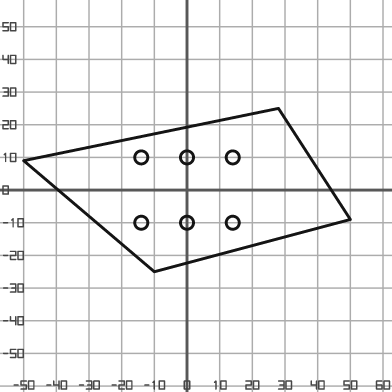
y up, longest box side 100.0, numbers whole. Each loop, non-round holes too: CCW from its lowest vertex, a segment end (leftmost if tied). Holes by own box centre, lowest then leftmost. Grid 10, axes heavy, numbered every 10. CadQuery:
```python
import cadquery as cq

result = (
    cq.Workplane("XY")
    .moveTo(-10.0, -25.0)
    .lineTo(50.0, -9.0)
    .lineTo(28.0, 25.0)
    .lineTo(-50.0, 9.0)
    .close()
    .moveTo(-14.0, -10.0)
    .circle(2.0)
    .moveTo(0.0, -10.0)
    .circle(2.0)
    .moveTo(14.0, -10.0)
    .circle(2.0)
    .moveTo(-14.0, 10.0)
    .circle(2.0)
    .moveTo(0.0, 10.0)
    .circle(2.0)
    .moveTo(14.0, 10.0)
    .circle(2.0)
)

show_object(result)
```